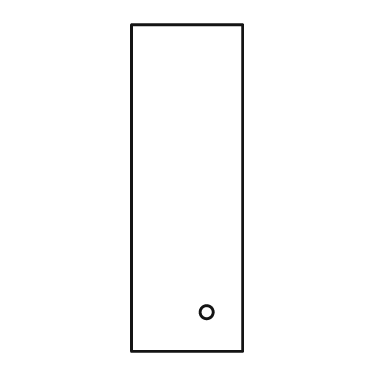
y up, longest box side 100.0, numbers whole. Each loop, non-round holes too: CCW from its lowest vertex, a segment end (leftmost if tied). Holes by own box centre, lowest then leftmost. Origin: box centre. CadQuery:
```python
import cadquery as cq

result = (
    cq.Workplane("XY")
    .moveTo(-17.0, -50.0)
    .lineTo(17.0, -50.0)
    .lineTo(17.0, 50.0)
    .lineTo(-17.0, 50.0)
    .close()
    .moveTo(6.0, -38.0)
    .circle(2.0)
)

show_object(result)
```